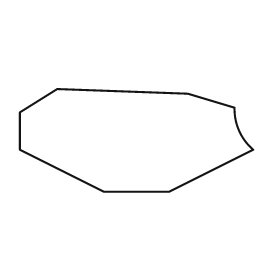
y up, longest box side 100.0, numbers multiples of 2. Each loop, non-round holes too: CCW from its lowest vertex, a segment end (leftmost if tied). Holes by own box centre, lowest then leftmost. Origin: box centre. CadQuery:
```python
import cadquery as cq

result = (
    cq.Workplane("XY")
    .moveTo(-14.0, -22.0)
    .lineTo(14.0, -22.0)
    .lineTo(50.0, -4.0)
    .threePointArc((44.0, 4.0), (42.0, 14.0))
    .lineTo(22.0, 20.0)
    .lineTo(-34.0, 22.0)
    .lineTo(-50.0, 12.0)
    .lineTo(-50.0, -4.0)
    .close()
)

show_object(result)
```